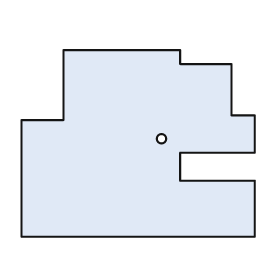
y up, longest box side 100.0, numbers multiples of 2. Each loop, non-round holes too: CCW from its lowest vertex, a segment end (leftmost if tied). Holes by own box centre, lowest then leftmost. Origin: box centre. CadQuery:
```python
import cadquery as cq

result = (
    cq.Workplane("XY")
    .moveTo(-50.0, -40.0)
    .lineTo(50.0, -40.0)
    .lineTo(50.0, -16.0)
    .lineTo(18.0, -16.0)
    .lineTo(18.0, -4.0)
    .lineTo(50.0, -4.0)
    .lineTo(50.0, 12.0)
    .lineTo(40.0, 12.0)
    .lineTo(40.0, 34.0)
    .lineTo(18.0, 34.0)
    .lineTo(18.0, 40.0)
    .lineTo(-32.0, 40.0)
    .lineTo(-32.0, 10.0)
    .lineTo(-50.0, 10.0)
    .close()
    .moveTo(10.0, 2.0)
    .circle(2.0)
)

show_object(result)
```